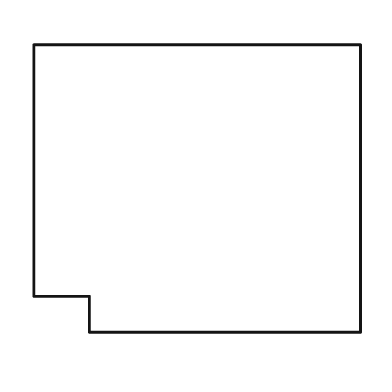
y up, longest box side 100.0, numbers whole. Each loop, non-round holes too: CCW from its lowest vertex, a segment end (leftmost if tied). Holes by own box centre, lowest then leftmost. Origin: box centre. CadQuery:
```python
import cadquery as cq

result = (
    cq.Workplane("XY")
    .moveTo(-33.0, -44.0)
    .lineTo(50.0, -44.0)
    .lineTo(50.0, 44.0)
    .lineTo(-50.0, 44.0)
    .lineTo(-50.0, -33.0)
    .lineTo(-33.0, -33.0)
    .close()
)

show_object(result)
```